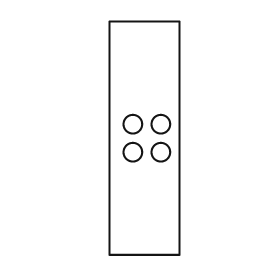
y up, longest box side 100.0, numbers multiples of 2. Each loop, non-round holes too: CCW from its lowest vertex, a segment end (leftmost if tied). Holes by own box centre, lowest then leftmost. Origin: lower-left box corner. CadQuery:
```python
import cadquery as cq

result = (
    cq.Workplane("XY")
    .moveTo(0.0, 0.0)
    .lineTo(30.0, 0.0)
    .lineTo(30.0, 100.0)
    .lineTo(0.0, 100.0)
    .close()
    .moveTo(10.0, 44.0)
    .circle(4.0)
    .moveTo(22.0, 44.0)
    .circle(4.0)
    .moveTo(10.0, 56.0)
    .circle(4.0)
    .moveTo(22.0, 56.0)
    .circle(4.0)
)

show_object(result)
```